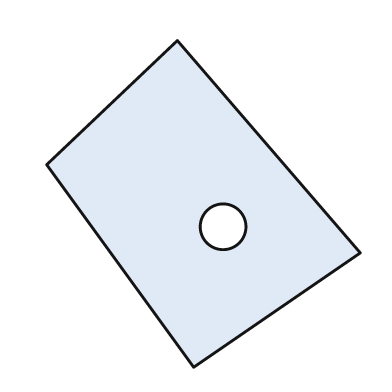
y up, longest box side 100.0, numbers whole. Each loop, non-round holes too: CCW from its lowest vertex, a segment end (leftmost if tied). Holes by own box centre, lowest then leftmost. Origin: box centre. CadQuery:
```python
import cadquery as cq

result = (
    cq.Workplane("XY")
    .moveTo(-3.0, -50.0)
    .lineTo(48.0, -15.0)
    .lineTo(-8.0, 50.0)
    .lineTo(-48.0, 12.0)
    .close()
    .moveTo(6.0, -7.0)
    .circle(7.0)
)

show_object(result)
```